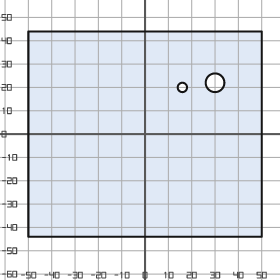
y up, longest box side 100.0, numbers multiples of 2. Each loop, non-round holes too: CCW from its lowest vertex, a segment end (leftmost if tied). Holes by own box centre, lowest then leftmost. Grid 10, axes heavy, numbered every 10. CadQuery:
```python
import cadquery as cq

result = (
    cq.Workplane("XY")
    .moveTo(-50.0, -44.0)
    .lineTo(50.0, -44.0)
    .lineTo(50.0, 44.0)
    .lineTo(-50.0, 44.0)
    .close()
    .moveTo(16.0, 20.0)
    .circle(2.0)
    .moveTo(30.0, 22.0)
    .circle(4.0)
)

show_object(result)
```